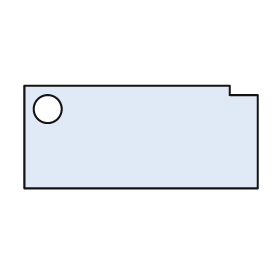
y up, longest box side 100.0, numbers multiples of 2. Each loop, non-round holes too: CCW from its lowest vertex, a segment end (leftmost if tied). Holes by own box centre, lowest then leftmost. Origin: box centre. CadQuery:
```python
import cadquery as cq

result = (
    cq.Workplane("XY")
    .moveTo(-50.0, -22.0)
    .lineTo(50.0, -22.0)
    .lineTo(50.0, 18.0)
    .lineTo(38.0, 18.0)
    .lineTo(38.0, 22.0)
    .lineTo(-50.0, 22.0)
    .close()
    .moveTo(-40.0, 12.0)
    .circle(6.0)
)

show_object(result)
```